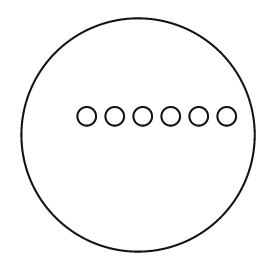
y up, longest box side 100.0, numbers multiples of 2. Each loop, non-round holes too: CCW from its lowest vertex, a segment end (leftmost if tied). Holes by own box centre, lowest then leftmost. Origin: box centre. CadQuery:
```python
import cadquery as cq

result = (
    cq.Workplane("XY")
    .moveTo(0.0, 0.0)
    .circle(50.0)
    .moveTo(-22.0, 8.0)
    .circle(4.0)
    .moveTo(-10.0, 8.0)
    .circle(4.0)
    .moveTo(2.0, 8.0)
    .circle(4.0)
    .moveTo(14.0, 8.0)
    .circle(4.0)
    .moveTo(26.0, 8.0)
    .circle(4.0)
    .moveTo(38.0, 8.0)
    .circle(4.0)
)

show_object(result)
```